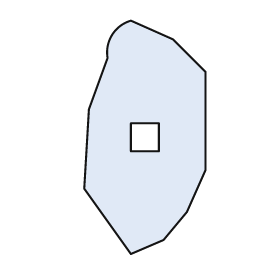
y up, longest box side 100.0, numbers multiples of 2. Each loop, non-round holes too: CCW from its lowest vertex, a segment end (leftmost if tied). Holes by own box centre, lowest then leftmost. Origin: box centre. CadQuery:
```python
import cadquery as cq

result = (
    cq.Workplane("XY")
    .moveTo(-6.0, -50.0)
    .lineTo(8.0, -44.0)
    .lineTo(18.0, -32.0)
    .lineTo(26.0, -14.0)
    .lineTo(26.0, 28.0)
    .lineTo(12.0, 42.0)
    .lineTo(-6.0, 50.0)
    .threePointArc((-14.0, 44.0), (-16.0, 34.0))
    .lineTo(-24.0, 12.0)
    .lineTo(-26.0, -22.0)
    .close()
    .moveTo(-6.0, -6.0)
    .lineTo(6.0, -6.0)
    .lineTo(6.0, 6.0)
    .lineTo(-6.0, 6.0)
    .close()
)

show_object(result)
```